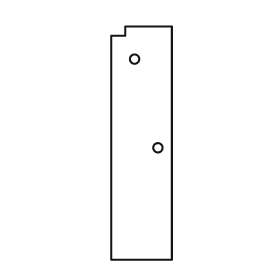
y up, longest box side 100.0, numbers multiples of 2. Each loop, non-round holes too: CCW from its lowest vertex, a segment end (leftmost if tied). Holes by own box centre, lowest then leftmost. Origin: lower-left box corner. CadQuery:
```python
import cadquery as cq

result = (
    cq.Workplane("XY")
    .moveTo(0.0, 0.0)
    .lineTo(26.0, 0.0)
    .lineTo(26.0, 100.0)
    .lineTo(6.0, 100.0)
    .lineTo(6.0, 96.0)
    .lineTo(0.0, 96.0)
    .close()
    .moveTo(20.0, 48.0)
    .circle(2.0)
    .moveTo(10.0, 86.0)
    .circle(2.0)
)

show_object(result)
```